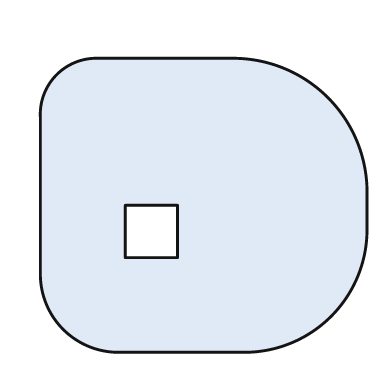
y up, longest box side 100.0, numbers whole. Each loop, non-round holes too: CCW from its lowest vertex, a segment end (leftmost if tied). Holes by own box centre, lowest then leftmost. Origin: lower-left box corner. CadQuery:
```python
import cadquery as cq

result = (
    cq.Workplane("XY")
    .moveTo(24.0, 0.0)
    .lineTo(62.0, 0.0)
    .threePointArc((89.0, 11.0), (100.0, 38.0))
    .lineTo(100.0, 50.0)
    .threePointArc((88.0, 78.0), (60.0, 90.0))
    .lineTo(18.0, 90.0)
    .threePointArc((5.0, 85.0), (0.0, 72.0))
    .lineTo(0.0, 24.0)
    .threePointArc((7.0, 7.0), (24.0, 0.0))
    .close()
    .moveTo(26.0, 29.0)
    .lineTo(42.0, 29.0)
    .lineTo(42.0, 45.0)
    .lineTo(26.0, 45.0)
    .close()
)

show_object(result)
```